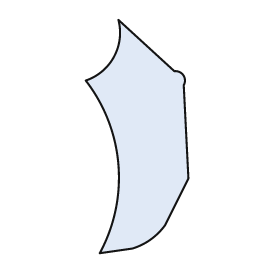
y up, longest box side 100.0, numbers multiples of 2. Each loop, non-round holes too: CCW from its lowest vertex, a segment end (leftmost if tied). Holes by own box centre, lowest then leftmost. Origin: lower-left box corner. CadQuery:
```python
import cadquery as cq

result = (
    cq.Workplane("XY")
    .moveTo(6.0, 0.0)
    .lineTo(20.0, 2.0)
    .threePointArc((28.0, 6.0), (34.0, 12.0))
    .lineTo(44.0, 32.0)
    .lineTo(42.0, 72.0)
    .threePointArc((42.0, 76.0), (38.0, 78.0))
    .lineTo(14.0, 100.0)
    .threePointArc((12.0, 84.0), (0.0, 74.0))
    .threePointArc((14.0, 38.0), (6.0, 0.0))
    .close()
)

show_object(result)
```